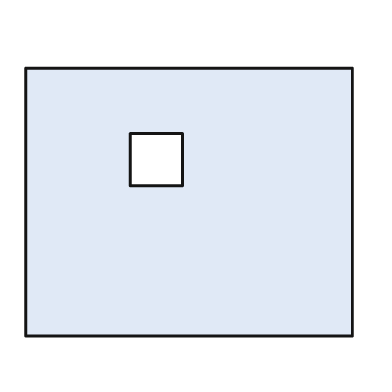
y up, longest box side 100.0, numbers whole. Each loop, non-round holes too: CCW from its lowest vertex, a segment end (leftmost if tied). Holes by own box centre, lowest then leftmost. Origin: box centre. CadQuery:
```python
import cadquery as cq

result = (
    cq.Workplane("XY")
    .moveTo(-50.0, -41.0)
    .lineTo(50.0, -41.0)
    .lineTo(50.0, 41.0)
    .lineTo(-50.0, 41.0)
    .close()
    .moveTo(-18.0, 5.0)
    .lineTo(-2.0, 5.0)
    .lineTo(-2.0, 21.0)
    .lineTo(-18.0, 21.0)
    .close()
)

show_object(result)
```